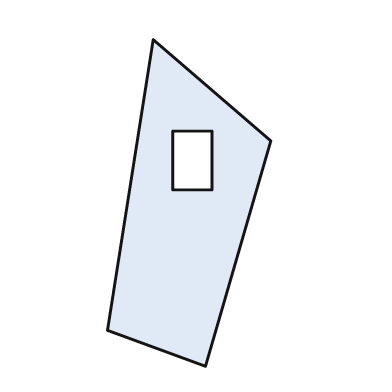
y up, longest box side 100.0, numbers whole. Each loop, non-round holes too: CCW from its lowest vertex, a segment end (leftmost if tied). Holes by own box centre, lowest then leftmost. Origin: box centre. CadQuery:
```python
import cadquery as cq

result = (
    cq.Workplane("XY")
    .moveTo(5.0, -50.0)
    .lineTo(25.0, 19.0)
    .lineTo(-11.0, 50.0)
    .lineTo(-25.0, -39.0)
    .close()
    .moveTo(-5.0, 4.0)
    .lineTo(7.0, 4.0)
    .lineTo(7.0, 22.0)
    .lineTo(-5.0, 22.0)
    .close()
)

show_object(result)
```